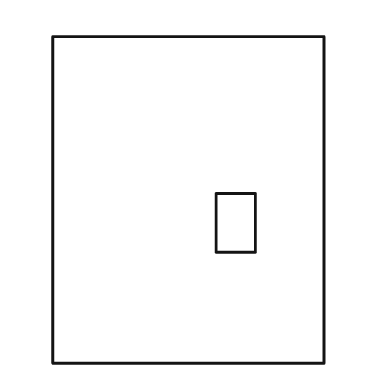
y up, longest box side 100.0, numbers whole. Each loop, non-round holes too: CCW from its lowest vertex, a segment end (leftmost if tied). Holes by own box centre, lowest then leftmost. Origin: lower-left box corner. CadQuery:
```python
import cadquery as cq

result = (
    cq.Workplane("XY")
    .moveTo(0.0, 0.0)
    .lineTo(83.0, 0.0)
    .lineTo(83.0, 100.0)
    .lineTo(0.0, 100.0)
    .close()
    .moveTo(50.0, 34.0)
    .lineTo(62.0, 34.0)
    .lineTo(62.0, 52.0)
    .lineTo(50.0, 52.0)
    .close()
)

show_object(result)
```